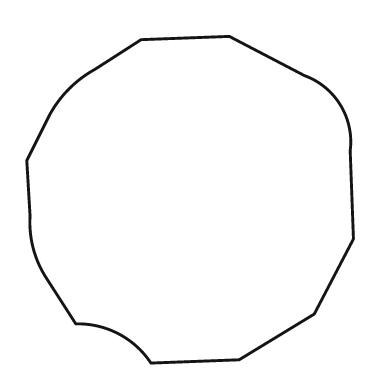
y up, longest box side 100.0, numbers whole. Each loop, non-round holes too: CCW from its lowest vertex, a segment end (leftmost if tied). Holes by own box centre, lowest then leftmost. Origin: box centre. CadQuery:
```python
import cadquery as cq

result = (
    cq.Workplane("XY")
    .moveTo(-12.0, -50.0)
    .lineTo(15.0, -49.0)
    .lineTo(38.0, -35.0)
    .lineTo(50.0, -12.0)
    .lineTo(49.0, 15.0)
    .threePointArc((46.0, 29.0), (35.0, 38.0))
    .lineTo(12.0, 50.0)
    .lineTo(-15.0, 49.0)
    .lineTo(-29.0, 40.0)
    .threePointArc((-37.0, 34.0), (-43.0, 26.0))
    .lineTo(-50.0, 12.0)
    .lineTo(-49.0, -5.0)
    .threePointArc((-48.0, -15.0), (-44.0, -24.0))
    .lineTo(-35.0, -38.0)
    .threePointArc((-22.0, -41.0), (-12.0, -50.0))
    .close()
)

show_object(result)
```